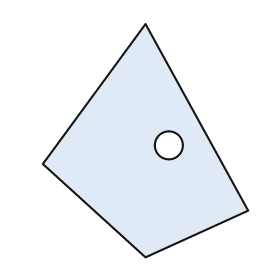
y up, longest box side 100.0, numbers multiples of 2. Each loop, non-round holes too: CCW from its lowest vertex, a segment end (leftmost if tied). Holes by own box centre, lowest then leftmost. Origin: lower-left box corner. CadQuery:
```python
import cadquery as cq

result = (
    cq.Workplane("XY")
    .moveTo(44.0, 0.0)
    .lineTo(88.0, 20.0)
    .lineTo(44.0, 100.0)
    .lineTo(0.0, 40.0)
    .close()
    .moveTo(54.0, 48.0)
    .circle(6.0)
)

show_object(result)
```